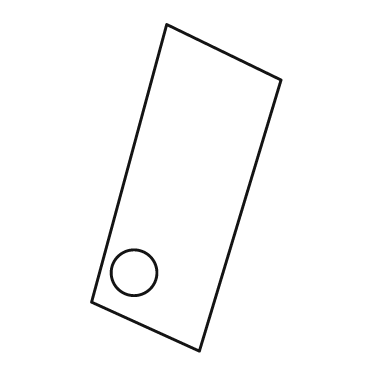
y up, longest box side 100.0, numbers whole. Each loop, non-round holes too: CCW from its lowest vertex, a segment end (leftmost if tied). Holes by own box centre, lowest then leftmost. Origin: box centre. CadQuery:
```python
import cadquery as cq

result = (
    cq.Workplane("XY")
    .moveTo(4.0, -50.0)
    .lineTo(29.0, 33.0)
    .lineTo(-6.0, 50.0)
    .lineTo(-29.0, -35.0)
    .close()
    .moveTo(-16.0, -26.0)
    .circle(7.0)
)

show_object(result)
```